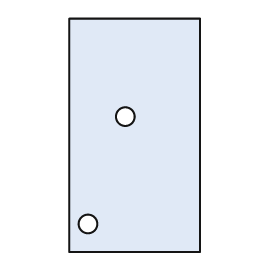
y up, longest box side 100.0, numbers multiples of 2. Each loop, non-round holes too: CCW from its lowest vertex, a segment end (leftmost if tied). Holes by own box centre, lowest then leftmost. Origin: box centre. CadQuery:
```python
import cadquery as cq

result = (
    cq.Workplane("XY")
    .moveTo(-28.0, -50.0)
    .lineTo(28.0, -50.0)
    .lineTo(28.0, 50.0)
    .lineTo(-28.0, 50.0)
    .close()
    .moveTo(-20.0, -38.0)
    .circle(4.0)
    .moveTo(-4.0, 8.0)
    .circle(4.0)
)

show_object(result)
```